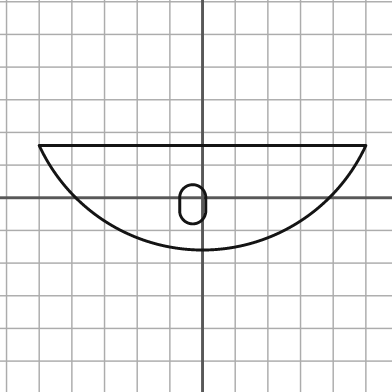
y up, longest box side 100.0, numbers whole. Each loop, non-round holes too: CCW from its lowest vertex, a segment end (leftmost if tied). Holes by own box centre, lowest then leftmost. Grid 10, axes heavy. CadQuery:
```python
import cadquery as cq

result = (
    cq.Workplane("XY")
    .moveTo(-50.0, 16.0)
    .threePointArc((0.0, -16.0), (50.0, 16.0))
    .close()
    .moveTo(-7.0, -4.0)
    .threePointArc((-3.0, -8.0), (1.0, -4.0))
    .lineTo(1.0, 0.0)
    .threePointArc((-3.0, 4.0), (-7.0, 0.0))
    .close()
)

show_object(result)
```